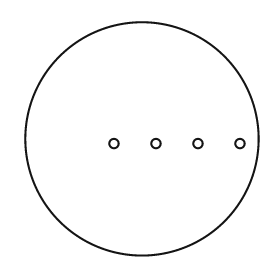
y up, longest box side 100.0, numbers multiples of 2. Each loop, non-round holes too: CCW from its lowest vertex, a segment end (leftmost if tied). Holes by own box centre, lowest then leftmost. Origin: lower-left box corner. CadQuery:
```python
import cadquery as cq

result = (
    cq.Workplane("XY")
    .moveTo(50.0, 50.0)
    .circle(50.0)
    .moveTo(38.0, 48.0)
    .circle(2.0)
    .moveTo(56.0, 48.0)
    .circle(2.0)
    .moveTo(74.0, 48.0)
    .circle(2.0)
    .moveTo(92.0, 48.0)
    .circle(2.0)
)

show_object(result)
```